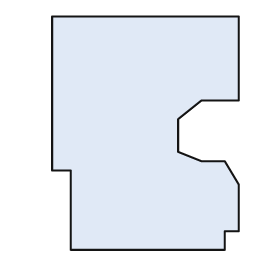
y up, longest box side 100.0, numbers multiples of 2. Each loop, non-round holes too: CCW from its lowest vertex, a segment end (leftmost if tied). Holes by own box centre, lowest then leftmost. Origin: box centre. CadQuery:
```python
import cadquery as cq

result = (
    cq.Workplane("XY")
    .moveTo(-32.0, -50.0)
    .lineTo(34.0, -50.0)
    .lineTo(34.0, -42.0)
    .lineTo(40.0, -42.0)
    .lineTo(40.0, -22.0)
    .lineTo(34.0, -12.0)
    .lineTo(24.0, -12.0)
    .lineTo(14.0, -8.0)
    .lineTo(14.0, 6.0)
    .lineTo(24.0, 14.0)
    .lineTo(40.0, 14.0)
    .lineTo(40.0, 50.0)
    .lineTo(-40.0, 50.0)
    .lineTo(-40.0, -16.0)
    .lineTo(-32.0, -16.0)
    .close()
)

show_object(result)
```